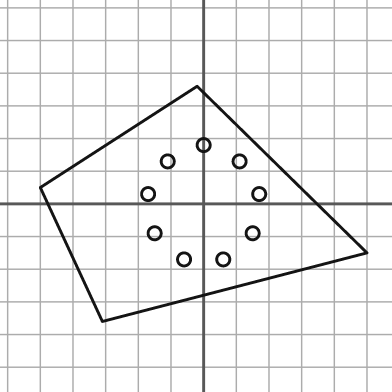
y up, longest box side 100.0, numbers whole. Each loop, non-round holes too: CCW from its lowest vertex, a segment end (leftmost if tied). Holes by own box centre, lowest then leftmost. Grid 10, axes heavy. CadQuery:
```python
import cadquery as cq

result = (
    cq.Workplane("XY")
    .moveTo(-31.0, -36.0)
    .lineTo(50.0, -15.0)
    .lineTo(-2.0, 36.0)
    .lineTo(-50.0, 5.0)
    .close()
    .moveTo(-6.0, -17.0)
    .circle(2.0)
    .moveTo(6.0, -17.0)
    .circle(2.0)
    .moveTo(-15.0, -9.0)
    .circle(2.0)
    .moveTo(15.0, -9.0)
    .circle(2.0)
    .moveTo(-17.0, 3.0)
    .circle(2.0)
    .moveTo(17.0, 3.0)
    .circle(2.0)
    .moveTo(-11.0, 13.0)
    .circle(2.0)
    .moveTo(11.0, 13.0)
    .circle(2.0)
    .moveTo(0.0, 18.0)
    .circle(2.0)
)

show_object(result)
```